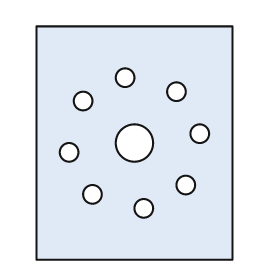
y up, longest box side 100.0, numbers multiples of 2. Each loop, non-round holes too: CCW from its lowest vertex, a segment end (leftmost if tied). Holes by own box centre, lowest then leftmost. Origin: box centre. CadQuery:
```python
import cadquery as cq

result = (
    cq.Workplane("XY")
    .moveTo(-42.0, -50.0)
    .lineTo(42.0, -50.0)
    .lineTo(42.0, 50.0)
    .lineTo(-42.0, 50.0)
    .close()
    .moveTo(4.0, -28.0)
    .circle(4.0)
    .moveTo(-18.0, -22.0)
    .circle(4.0)
    .moveTo(22.0, -18.0)
    .circle(4.0)
    .moveTo(-28.0, -4.0)
    .circle(4.0)
    .moveTo(0.0, 0.0)
    .circle(8.0)
    .moveTo(28.0, 4.0)
    .circle(4.0)
    .moveTo(-22.0, 18.0)
    .circle(4.0)
    .moveTo(18.0, 22.0)
    .circle(4.0)
    .moveTo(-4.0, 28.0)
    .circle(4.0)
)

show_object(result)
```